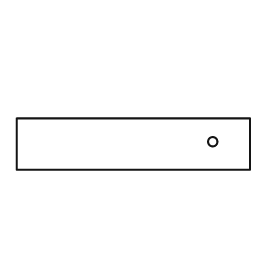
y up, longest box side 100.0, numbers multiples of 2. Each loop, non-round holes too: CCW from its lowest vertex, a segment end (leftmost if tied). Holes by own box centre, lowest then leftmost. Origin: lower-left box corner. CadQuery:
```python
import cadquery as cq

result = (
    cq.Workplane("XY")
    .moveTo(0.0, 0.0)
    .lineTo(100.0, 0.0)
    .lineTo(100.0, 22.0)
    .lineTo(0.0, 22.0)
    .close()
    .moveTo(84.0, 12.0)
    .circle(2.0)
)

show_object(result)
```